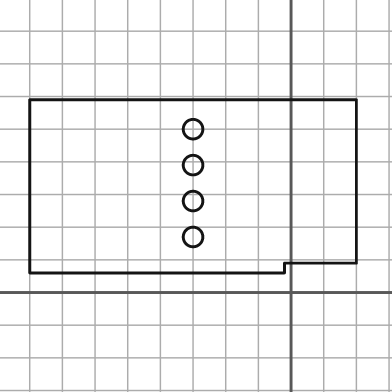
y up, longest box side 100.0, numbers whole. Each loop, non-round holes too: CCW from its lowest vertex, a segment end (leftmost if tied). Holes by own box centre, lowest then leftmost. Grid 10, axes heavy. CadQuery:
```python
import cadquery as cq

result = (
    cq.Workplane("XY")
    .moveTo(-80.0, 6.0)
    .lineTo(-2.0, 6.0)
    .lineTo(-2.0, 9.0)
    .lineTo(20.0, 9.0)
    .lineTo(20.0, 59.0)
    .lineTo(-80.0, 59.0)
    .close()
    .moveTo(-30.0, 17.0)
    .circle(3.0)
    .moveTo(-30.0, 28.0)
    .circle(3.0)
    .moveTo(-30.0, 39.0)
    .circle(3.0)
    .moveTo(-30.0, 50.0)
    .circle(3.0)
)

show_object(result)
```